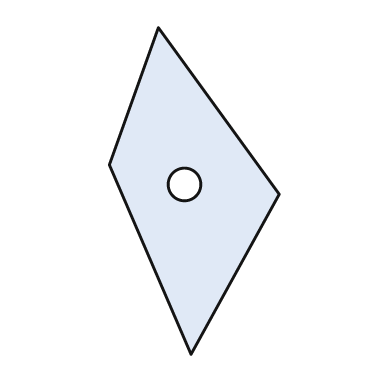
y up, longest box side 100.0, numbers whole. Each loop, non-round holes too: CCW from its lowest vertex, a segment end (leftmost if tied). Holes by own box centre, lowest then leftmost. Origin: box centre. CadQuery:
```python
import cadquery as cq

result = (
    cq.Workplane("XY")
    .moveTo(-1.0, -50.0)
    .lineTo(26.0, -1.0)
    .lineTo(-11.0, 50.0)
    .lineTo(-26.0, 8.0)
    .close()
    .moveTo(-3.0, 2.0)
    .circle(5.0)
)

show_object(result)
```